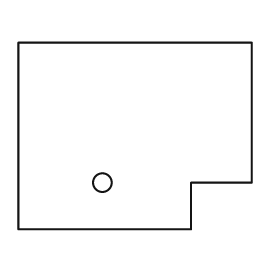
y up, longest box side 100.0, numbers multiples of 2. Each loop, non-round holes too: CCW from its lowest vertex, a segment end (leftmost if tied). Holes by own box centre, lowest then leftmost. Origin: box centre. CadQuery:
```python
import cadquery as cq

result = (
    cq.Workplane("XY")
    .moveTo(-50.0, -40.0)
    .lineTo(24.0, -40.0)
    .lineTo(24.0, -20.0)
    .lineTo(50.0, -20.0)
    .lineTo(50.0, 40.0)
    .lineTo(-50.0, 40.0)
    .close()
    .moveTo(-14.0, -20.0)
    .circle(4.0)
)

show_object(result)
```